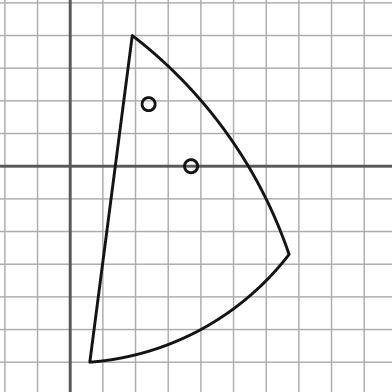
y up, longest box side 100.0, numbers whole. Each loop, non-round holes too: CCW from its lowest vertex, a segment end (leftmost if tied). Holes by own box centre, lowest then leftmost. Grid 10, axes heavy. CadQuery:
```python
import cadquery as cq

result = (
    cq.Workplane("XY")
    .moveTo(6.0, -60.0)
    .threePointArc((40.0, -50.0), (67.0, -27.0))
    .threePointArc((48.0, 10.0), (19.0, 40.0))
    .close()
    .moveTo(37.0, 0.0)
    .circle(2.0)
    .moveTo(24.0, 19.0)
    .circle(2.0)
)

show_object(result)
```